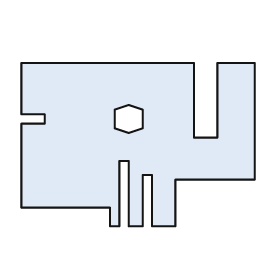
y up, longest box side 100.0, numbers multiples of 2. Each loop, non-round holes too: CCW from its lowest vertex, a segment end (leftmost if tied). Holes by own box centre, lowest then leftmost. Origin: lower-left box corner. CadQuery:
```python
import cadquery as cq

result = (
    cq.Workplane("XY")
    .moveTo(38.0, 0.0)
    .lineTo(42.0, 0.0)
    .lineTo(42.0, 28.0)
    .lineTo(46.0, 28.0)
    .lineTo(46.0, 0.0)
    .lineTo(52.0, 0.0)
    .lineTo(52.0, 22.0)
    .lineTo(56.0, 22.0)
    .lineTo(56.0, 0.0)
    .lineTo(66.0, 0.0)
    .lineTo(66.0, 20.0)
    .lineTo(100.0, 20.0)
    .lineTo(100.0, 70.0)
    .lineTo(84.0, 70.0)
    .lineTo(84.0, 38.0)
    .lineTo(74.0, 38.0)
    .lineTo(74.0, 70.0)
    .lineTo(0.0, 70.0)
    .lineTo(0.0, 48.0)
    .lineTo(10.0, 48.0)
    .lineTo(10.0, 44.0)
    .lineTo(0.0, 44.0)
    .lineTo(0.0, 8.0)
    .lineTo(38.0, 8.0)
    .close()
    .moveTo(46.0, 40.0)
    .lineTo(52.0, 42.0)
    .lineTo(52.0, 50.0)
    .lineTo(46.0, 52.0)
    .lineTo(40.0, 50.0)
    .lineTo(40.0, 42.0)
    .close()
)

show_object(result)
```